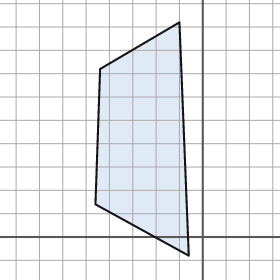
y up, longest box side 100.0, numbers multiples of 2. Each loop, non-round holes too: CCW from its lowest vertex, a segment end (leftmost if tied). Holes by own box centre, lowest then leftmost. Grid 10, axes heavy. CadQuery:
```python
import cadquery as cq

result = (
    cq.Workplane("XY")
    .moveTo(-6.0, -8.0)
    .lineTo(-10.0, 92.0)
    .lineTo(-44.0, 72.0)
    .lineTo(-46.0, 14.0)
    .close()
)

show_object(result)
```